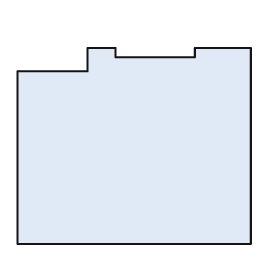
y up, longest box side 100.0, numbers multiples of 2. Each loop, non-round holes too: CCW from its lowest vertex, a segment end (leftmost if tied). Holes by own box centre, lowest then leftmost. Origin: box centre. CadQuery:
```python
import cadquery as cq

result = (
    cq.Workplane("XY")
    .moveTo(-50.0, -42.0)
    .lineTo(50.0, -42.0)
    .lineTo(50.0, 42.0)
    .lineTo(26.0, 42.0)
    .lineTo(26.0, 38.0)
    .lineTo(-8.0, 38.0)
    .lineTo(-8.0, 42.0)
    .lineTo(-20.0, 42.0)
    .lineTo(-20.0, 32.0)
    .lineTo(-50.0, 32.0)
    .close()
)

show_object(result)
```